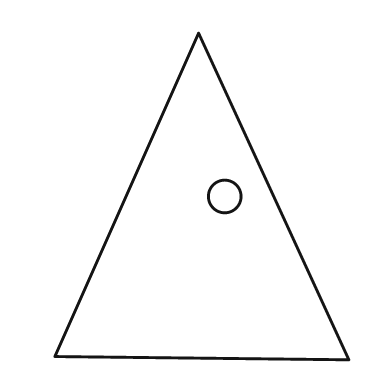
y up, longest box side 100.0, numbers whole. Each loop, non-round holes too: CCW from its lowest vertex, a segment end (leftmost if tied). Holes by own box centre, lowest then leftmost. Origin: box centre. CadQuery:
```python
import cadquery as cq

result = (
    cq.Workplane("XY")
    .moveTo(45.0, -50.0)
    .lineTo(-1.0, 50.0)
    .lineTo(-45.0, -49.0)
    .close()
    .moveTo(7.0, 0.0)
    .circle(5.0)
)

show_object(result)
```